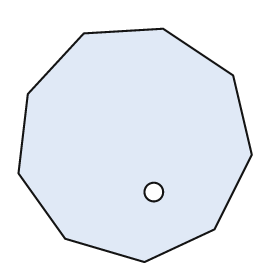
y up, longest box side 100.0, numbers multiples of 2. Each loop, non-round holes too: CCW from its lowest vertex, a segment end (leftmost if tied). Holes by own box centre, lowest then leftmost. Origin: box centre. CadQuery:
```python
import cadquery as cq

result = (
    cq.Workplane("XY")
    .moveTo(4.0, -50.0)
    .lineTo(34.0, -36.0)
    .lineTo(50.0, -4.0)
    .lineTo(42.0, 30.0)
    .lineTo(12.0, 50.0)
    .lineTo(-22.0, 48.0)
    .lineTo(-46.0, 22.0)
    .lineTo(-50.0, -12.0)
    .lineTo(-30.0, -40.0)
    .close()
    .moveTo(8.0, -20.0)
    .circle(4.0)
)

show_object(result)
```